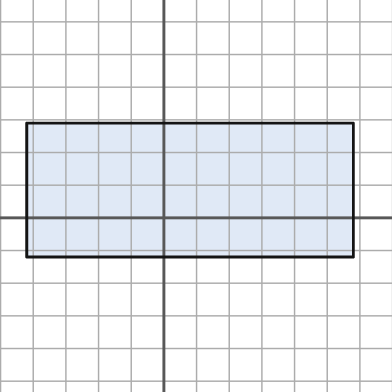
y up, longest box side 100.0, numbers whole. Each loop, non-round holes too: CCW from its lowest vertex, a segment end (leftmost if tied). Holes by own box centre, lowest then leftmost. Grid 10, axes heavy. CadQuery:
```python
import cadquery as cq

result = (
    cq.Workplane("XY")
    .moveTo(-42.0, -12.0)
    .lineTo(58.0, -12.0)
    .lineTo(58.0, 29.0)
    .lineTo(-42.0, 29.0)
    .close()
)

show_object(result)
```